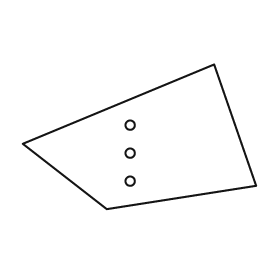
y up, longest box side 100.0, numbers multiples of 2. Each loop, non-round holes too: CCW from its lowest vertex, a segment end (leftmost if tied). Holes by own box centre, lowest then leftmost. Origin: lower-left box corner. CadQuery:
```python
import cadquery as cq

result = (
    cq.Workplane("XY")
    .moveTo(36.0, 0.0)
    .lineTo(100.0, 10.0)
    .lineTo(82.0, 62.0)
    .lineTo(0.0, 28.0)
    .close()
    .moveTo(46.0, 12.0)
    .circle(2.0)
    .moveTo(46.0, 24.0)
    .circle(2.0)
    .moveTo(46.0, 36.0)
    .circle(2.0)
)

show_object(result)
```